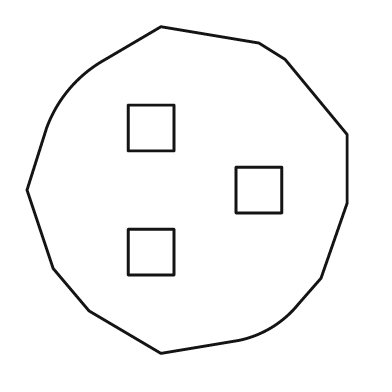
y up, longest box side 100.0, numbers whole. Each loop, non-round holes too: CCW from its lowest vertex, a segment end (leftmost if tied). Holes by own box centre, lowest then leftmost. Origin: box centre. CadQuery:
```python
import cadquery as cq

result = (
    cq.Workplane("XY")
    .moveTo(-8.0, -50.0)
    .lineTo(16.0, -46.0)
    .threePointArc((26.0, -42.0), (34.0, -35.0))
    .lineTo(41.0, -27.0)
    .lineTo(49.0, -4.0)
    .lineTo(49.0, 17.0)
    .lineTo(30.0, 40.0)
    .lineTo(22.0, 45.0)
    .lineTo(-8.0, 50.0)
    .lineTo(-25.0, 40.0)
    .threePointArc((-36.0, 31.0), (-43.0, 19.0))
    .lineTo(-49.0, 0.0)
    .lineTo(-41.0, -24.0)
    .lineTo(-30.0, -37.0)
    .close()
    .moveTo(-18.0, -26.0)
    .lineTo(-4.0, -26.0)
    .lineTo(-4.0, -12.0)
    .lineTo(-18.0, -12.0)
    .close()
    .moveTo(15.0, -7.0)
    .lineTo(29.0, -7.0)
    .lineTo(29.0, 7.0)
    .lineTo(15.0, 7.0)
    .close()
    .moveTo(-18.0, 12.0)
    .lineTo(-4.0, 12.0)
    .lineTo(-4.0, 26.0)
    .lineTo(-18.0, 26.0)
    .close()
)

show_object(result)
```